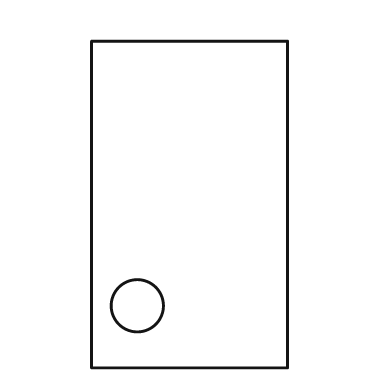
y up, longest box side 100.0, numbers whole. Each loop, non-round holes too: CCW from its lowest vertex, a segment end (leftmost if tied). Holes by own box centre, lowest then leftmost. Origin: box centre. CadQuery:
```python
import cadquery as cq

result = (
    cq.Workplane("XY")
    .moveTo(-30.0, -50.0)
    .lineTo(30.0, -50.0)
    .lineTo(30.0, 50.0)
    .lineTo(-30.0, 50.0)
    .close()
    .moveTo(-16.0, -31.0)
    .circle(8.0)
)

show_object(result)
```